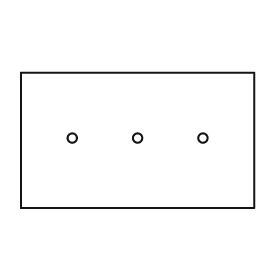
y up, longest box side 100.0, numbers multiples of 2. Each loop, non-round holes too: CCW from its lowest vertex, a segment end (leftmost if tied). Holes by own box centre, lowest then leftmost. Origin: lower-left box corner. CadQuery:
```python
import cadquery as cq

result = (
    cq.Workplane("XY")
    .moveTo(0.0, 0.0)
    .lineTo(100.0, 0.0)
    .lineTo(100.0, 58.0)
    .lineTo(0.0, 58.0)
    .close()
    .moveTo(22.0, 30.0)
    .circle(2.0)
    .moveTo(50.0, 30.0)
    .circle(2.0)
    .moveTo(78.0, 30.0)
    .circle(2.0)
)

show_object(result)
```